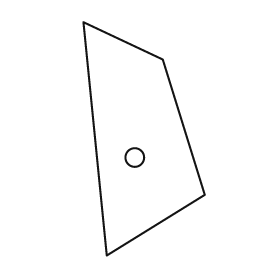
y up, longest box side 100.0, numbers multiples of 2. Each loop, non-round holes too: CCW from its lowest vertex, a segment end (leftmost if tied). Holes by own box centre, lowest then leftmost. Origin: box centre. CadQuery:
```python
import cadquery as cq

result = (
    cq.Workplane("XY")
    .moveTo(-16.0, -50.0)
    .lineTo(26.0, -24.0)
    .lineTo(8.0, 34.0)
    .lineTo(-26.0, 50.0)
    .close()
    .moveTo(-4.0, -8.0)
    .circle(4.0)
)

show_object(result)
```